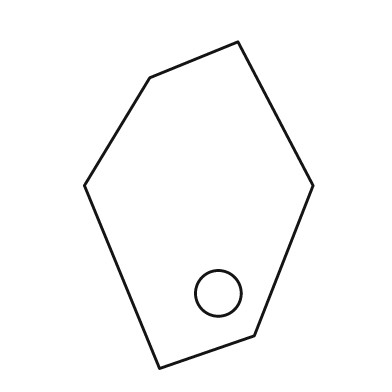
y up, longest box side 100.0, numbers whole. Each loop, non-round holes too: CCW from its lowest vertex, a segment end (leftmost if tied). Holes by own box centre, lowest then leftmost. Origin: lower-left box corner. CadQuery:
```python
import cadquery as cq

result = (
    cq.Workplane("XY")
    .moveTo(23.0, 0.0)
    .lineTo(52.0, 10.0)
    .lineTo(70.0, 56.0)
    .lineTo(47.0, 100.0)
    .lineTo(20.0, 89.0)
    .lineTo(0.0, 56.0)
    .close()
    .moveTo(41.0, 23.0)
    .circle(7.0)
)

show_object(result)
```